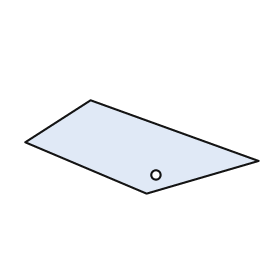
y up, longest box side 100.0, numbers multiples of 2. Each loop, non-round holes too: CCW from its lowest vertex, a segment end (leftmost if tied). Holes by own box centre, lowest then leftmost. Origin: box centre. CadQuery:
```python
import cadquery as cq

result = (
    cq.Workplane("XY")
    .moveTo(2.0, -20.0)
    .lineTo(50.0, -6.0)
    .lineTo(-22.0, 20.0)
    .lineTo(-50.0, 2.0)
    .close()
    .moveTo(6.0, -12.0)
    .circle(2.0)
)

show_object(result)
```